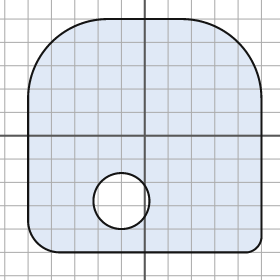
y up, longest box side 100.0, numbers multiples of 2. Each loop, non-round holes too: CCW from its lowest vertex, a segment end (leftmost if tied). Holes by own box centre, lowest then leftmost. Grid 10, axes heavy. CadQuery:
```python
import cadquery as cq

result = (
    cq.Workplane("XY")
    .moveTo(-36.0, -50.0)
    .lineTo(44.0, -50.0)
    .threePointArc((48.0, -48.0), (50.0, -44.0))
    .lineTo(50.0, 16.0)
    .threePointArc((40.0, 40.0), (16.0, 50.0))
    .lineTo(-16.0, 50.0)
    .threePointArc((-40.0, 40.0), (-50.0, 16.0))
    .lineTo(-50.0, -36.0)
    .threePointArc((-46.0, -46.0), (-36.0, -50.0))
    .close()
    .moveTo(-10.0, -28.0)
    .circle(12.0)
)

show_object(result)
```